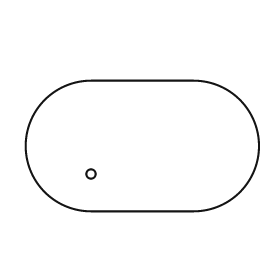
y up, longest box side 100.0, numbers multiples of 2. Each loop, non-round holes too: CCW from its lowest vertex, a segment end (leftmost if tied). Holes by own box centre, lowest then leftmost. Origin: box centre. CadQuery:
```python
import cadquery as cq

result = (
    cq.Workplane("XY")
    .moveTo(-22.0, -28.0)
    .lineTo(22.0, -28.0)
    .threePointArc((50.0, 0.0), (22.0, 28.0))
    .lineTo(-22.0, 28.0)
    .threePointArc((-50.0, 0.0), (-22.0, -28.0))
    .close()
    .moveTo(-22.0, -12.0)
    .circle(2.0)
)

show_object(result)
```